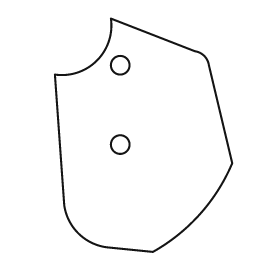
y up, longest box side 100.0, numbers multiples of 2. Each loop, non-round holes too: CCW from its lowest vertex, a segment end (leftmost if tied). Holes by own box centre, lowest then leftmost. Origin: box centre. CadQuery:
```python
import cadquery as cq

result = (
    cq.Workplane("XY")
    .moveTo(4.0, -50.0)
    .threePointArc((24.0, -34.0), (38.0, -12.0))
    .lineTo(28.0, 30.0)
    .threePointArc((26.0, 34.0), (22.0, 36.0))
    .lineTo(-14.0, 50.0)
    .threePointArc((-20.0, 32.0), (-38.0, 26.0))
    .lineTo(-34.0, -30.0)
    .threePointArc((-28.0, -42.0), (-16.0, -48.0))
    .close()
    .moveTo(-10.0, -4.0)
    .circle(4.0)
    .moveTo(-10.0, 30.0)
    .circle(4.0)
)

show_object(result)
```